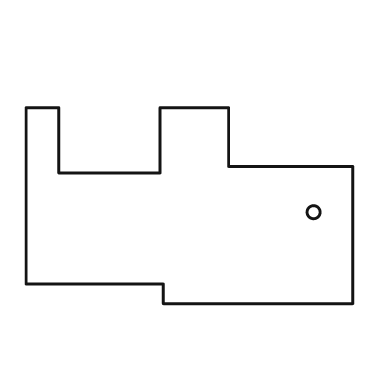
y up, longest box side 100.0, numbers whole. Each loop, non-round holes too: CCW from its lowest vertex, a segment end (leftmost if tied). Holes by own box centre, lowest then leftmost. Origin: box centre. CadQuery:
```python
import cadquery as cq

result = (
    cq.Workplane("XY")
    .moveTo(-8.0, -30.0)
    .lineTo(50.0, -30.0)
    .lineTo(50.0, 12.0)
    .lineTo(12.0, 12.0)
    .lineTo(12.0, 30.0)
    .lineTo(-9.0, 30.0)
    .lineTo(-9.0, 10.0)
    .lineTo(-40.0, 10.0)
    .lineTo(-40.0, 30.0)
    .lineTo(-50.0, 30.0)
    .lineTo(-50.0, -24.0)
    .lineTo(-8.0, -24.0)
    .close()
    .moveTo(38.0, -2.0)
    .circle(2.0)
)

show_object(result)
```